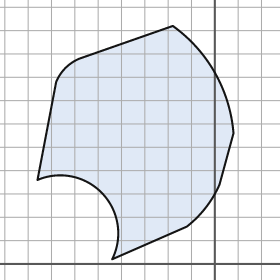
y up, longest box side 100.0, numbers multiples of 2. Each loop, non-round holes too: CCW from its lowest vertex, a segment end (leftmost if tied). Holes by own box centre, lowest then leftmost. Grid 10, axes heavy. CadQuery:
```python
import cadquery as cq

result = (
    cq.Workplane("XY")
    .moveTo(-44.0, 2.0)
    .lineTo(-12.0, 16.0)
    .threePointArc((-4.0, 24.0), (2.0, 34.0))
    .lineTo(8.0, 56.0)
    .threePointArc((0.0, 82.0), (-18.0, 102.0))
    .lineTo(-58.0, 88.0)
    .threePointArc((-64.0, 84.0), (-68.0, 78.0))
    .lineTo(-76.0, 36.0)
    .threePointArc((-48.0, 30.0), (-44.0, 2.0))
    .close()
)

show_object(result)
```